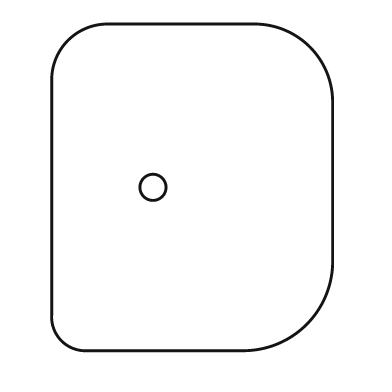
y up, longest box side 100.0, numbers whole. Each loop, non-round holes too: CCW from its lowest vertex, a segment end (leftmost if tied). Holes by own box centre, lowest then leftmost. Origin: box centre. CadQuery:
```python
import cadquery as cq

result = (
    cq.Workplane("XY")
    .moveTo(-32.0, -50.0)
    .lineTo(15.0, -50.0)
    .threePointArc((35.0, -42.0), (43.0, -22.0))
    .lineTo(43.0, 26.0)
    .threePointArc((36.0, 43.0), (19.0, 50.0))
    .lineTo(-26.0, 50.0)
    .threePointArc((-38.0, 45.0), (-43.0, 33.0))
    .lineTo(-43.0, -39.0)
    .threePointArc((-40.0, -47.0), (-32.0, -50.0))
    .close()
    .moveTo(-12.0, 0.0)
    .circle(4.0)
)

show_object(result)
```